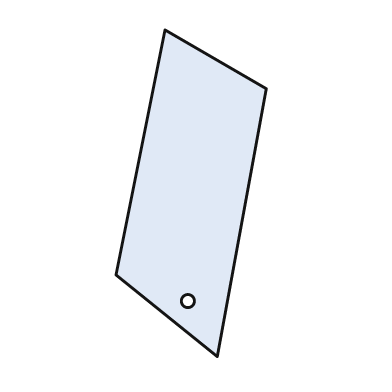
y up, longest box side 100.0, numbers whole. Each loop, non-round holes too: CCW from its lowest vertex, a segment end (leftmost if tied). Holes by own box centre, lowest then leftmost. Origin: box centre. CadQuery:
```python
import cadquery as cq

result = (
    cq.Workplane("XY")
    .moveTo(8.0, -50.0)
    .lineTo(23.0, 32.0)
    .lineTo(-8.0, 50.0)
    .lineTo(-23.0, -25.0)
    .close()
    .moveTo(-1.0, -33.0)
    .circle(2.0)
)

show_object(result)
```